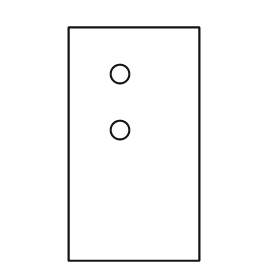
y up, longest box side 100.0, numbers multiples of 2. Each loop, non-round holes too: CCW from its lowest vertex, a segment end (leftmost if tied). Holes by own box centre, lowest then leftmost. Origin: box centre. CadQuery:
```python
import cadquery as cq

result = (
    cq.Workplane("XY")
    .moveTo(-28.0, -50.0)
    .lineTo(28.0, -50.0)
    .lineTo(28.0, 50.0)
    .lineTo(-28.0, 50.0)
    .close()
    .moveTo(-6.0, 6.0)
    .circle(4.0)
    .moveTo(-6.0, 30.0)
    .circle(4.0)
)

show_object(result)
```